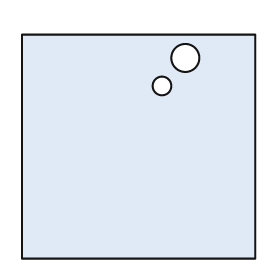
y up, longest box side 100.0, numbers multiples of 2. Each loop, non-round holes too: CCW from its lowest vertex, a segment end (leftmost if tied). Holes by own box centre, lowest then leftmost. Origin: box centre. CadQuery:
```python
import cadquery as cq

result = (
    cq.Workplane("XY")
    .moveTo(-50.0, -48.0)
    .lineTo(50.0, -48.0)
    .lineTo(50.0, 48.0)
    .lineTo(-50.0, 48.0)
    .close()
    .moveTo(10.0, 26.0)
    .circle(4.0)
    .moveTo(20.0, 38.0)
    .circle(6.0)
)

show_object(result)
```